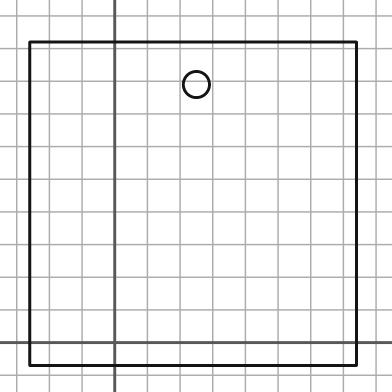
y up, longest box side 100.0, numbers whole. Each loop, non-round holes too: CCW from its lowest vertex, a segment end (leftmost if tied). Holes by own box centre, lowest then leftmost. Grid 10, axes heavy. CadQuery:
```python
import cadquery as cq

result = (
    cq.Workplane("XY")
    .moveTo(-26.0, -7.0)
    .lineTo(74.0, -7.0)
    .lineTo(74.0, 92.0)
    .lineTo(-26.0, 92.0)
    .close()
    .moveTo(25.0, 79.0)
    .circle(4.0)
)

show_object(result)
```